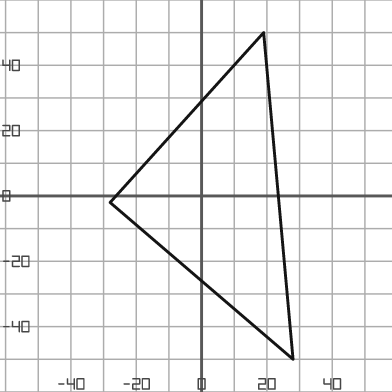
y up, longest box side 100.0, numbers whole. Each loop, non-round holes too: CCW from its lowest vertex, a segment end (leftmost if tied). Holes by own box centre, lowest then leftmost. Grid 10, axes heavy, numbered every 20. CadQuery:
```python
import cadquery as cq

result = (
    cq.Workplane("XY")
    .moveTo(28.0, -50.0)
    .lineTo(19.0, 50.0)
    .lineTo(-28.0, -2.0)
    .close()
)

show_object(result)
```